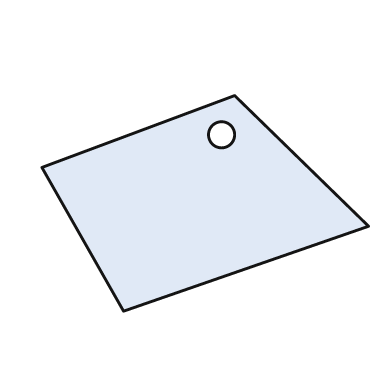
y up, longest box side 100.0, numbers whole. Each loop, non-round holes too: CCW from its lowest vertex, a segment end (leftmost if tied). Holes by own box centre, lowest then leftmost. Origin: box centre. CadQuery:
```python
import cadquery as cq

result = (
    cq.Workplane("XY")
    .moveTo(-25.0, -33.0)
    .lineTo(50.0, -7.0)
    .lineTo(9.0, 33.0)
    .lineTo(-50.0, 11.0)
    .close()
    .moveTo(5.0, 21.0)
    .circle(4.0)
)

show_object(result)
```